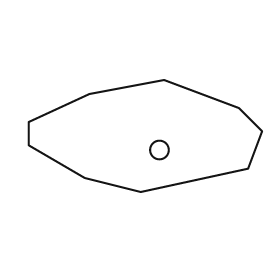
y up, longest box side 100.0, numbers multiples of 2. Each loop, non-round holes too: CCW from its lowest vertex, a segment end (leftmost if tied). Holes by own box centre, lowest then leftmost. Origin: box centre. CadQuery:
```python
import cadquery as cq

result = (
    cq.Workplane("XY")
    .moveTo(-2.0, -24.0)
    .lineTo(44.0, -14.0)
    .lineTo(50.0, 2.0)
    .lineTo(40.0, 12.0)
    .lineTo(8.0, 24.0)
    .lineTo(-24.0, 18.0)
    .lineTo(-50.0, 6.0)
    .lineTo(-50.0, -4.0)
    .lineTo(-26.0, -18.0)
    .close()
    .moveTo(6.0, -6.0)
    .circle(4.0)
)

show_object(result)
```